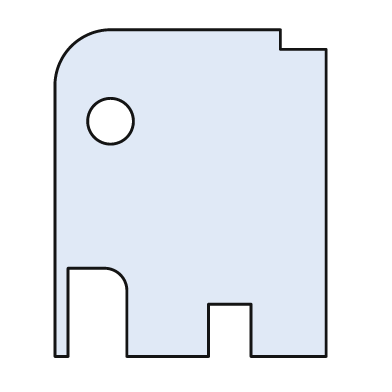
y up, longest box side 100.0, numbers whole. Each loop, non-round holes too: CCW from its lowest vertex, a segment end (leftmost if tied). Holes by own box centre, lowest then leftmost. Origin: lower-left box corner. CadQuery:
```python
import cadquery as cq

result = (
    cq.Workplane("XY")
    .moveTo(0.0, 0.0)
    .lineTo(4.0, 0.0)
    .lineTo(4.0, 27.0)
    .lineTo(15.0, 27.0)
    .threePointArc((20.0, 25.0), (22.0, 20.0))
    .lineTo(22.0, 0.0)
    .lineTo(47.0, 0.0)
    .lineTo(47.0, 16.0)
    .lineTo(60.0, 16.0)
    .lineTo(60.0, 0.0)
    .lineTo(83.0, 0.0)
    .lineTo(83.0, 94.0)
    .lineTo(69.0, 94.0)
    .lineTo(69.0, 100.0)
    .lineTo(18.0, 100.0)
    .threePointArc((5.0, 95.0), (0.0, 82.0))
    .close()
    .moveTo(17.0, 72.0)
    .circle(7.0)
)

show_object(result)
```